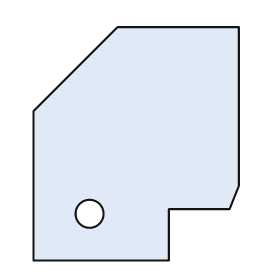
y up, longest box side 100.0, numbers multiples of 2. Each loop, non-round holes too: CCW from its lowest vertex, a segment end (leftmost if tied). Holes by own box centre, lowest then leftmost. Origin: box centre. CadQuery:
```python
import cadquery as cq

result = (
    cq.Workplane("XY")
    .moveTo(-44.0, -50.0)
    .lineTo(14.0, -50.0)
    .lineTo(14.0, -28.0)
    .lineTo(40.0, -28.0)
    .lineTo(44.0, -18.0)
    .lineTo(44.0, 50.0)
    .lineTo(-8.0, 50.0)
    .lineTo(-44.0, 14.0)
    .close()
    .moveTo(-20.0, -30.0)
    .circle(6.0)
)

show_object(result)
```